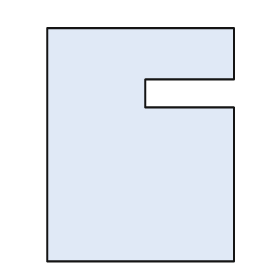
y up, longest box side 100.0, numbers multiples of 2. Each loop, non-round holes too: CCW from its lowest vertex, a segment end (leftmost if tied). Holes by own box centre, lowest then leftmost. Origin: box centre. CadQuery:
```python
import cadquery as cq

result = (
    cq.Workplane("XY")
    .moveTo(-40.0, -50.0)
    .lineTo(40.0, -50.0)
    .lineTo(40.0, 16.0)
    .lineTo(2.0, 16.0)
    .lineTo(2.0, 28.0)
    .lineTo(40.0, 28.0)
    .lineTo(40.0, 50.0)
    .lineTo(-40.0, 50.0)
    .close()
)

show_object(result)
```